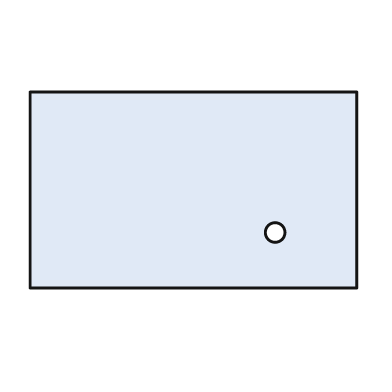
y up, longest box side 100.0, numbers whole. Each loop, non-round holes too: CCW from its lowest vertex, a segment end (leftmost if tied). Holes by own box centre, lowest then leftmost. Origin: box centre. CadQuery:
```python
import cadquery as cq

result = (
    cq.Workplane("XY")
    .moveTo(-50.0, -30.0)
    .lineTo(50.0, -30.0)
    .lineTo(50.0, 30.0)
    .lineTo(-50.0, 30.0)
    .close()
    .moveTo(25.0, -13.0)
    .circle(3.0)
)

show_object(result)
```